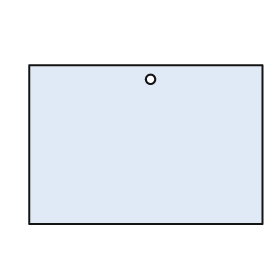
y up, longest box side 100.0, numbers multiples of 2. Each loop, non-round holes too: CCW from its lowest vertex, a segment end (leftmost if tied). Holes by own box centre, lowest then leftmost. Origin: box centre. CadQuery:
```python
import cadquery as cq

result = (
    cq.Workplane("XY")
    .moveTo(-50.0, -34.0)
    .lineTo(50.0, -34.0)
    .lineTo(50.0, 34.0)
    .lineTo(-50.0, 34.0)
    .close()
    .moveTo(2.0, 28.0)
    .circle(2.0)
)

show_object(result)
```